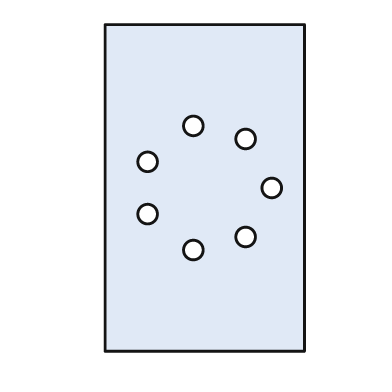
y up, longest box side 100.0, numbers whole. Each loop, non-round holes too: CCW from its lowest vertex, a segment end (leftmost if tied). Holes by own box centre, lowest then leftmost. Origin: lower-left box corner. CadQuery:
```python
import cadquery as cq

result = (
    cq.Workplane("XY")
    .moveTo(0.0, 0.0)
    .lineTo(61.0, 0.0)
    .lineTo(61.0, 100.0)
    .lineTo(0.0, 100.0)
    .close()
    .moveTo(27.0, 31.0)
    .circle(3.0)
    .moveTo(43.0, 35.0)
    .circle(3.0)
    .moveTo(13.0, 42.0)
    .circle(3.0)
    .moveTo(51.0, 50.0)
    .circle(3.0)
    .moveTo(13.0, 58.0)
    .circle(3.0)
    .moveTo(43.0, 65.0)
    .circle(3.0)
    .moveTo(27.0, 69.0)
    .circle(3.0)
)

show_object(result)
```